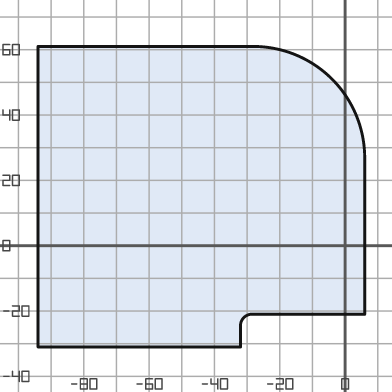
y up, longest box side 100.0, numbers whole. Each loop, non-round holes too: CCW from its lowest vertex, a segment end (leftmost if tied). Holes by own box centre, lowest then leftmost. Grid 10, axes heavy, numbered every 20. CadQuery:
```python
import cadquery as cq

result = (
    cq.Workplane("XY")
    .moveTo(-94.0, -31.0)
    .lineTo(-32.0, -31.0)
    .lineTo(-32.0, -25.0)
    .threePointArc((-31.0, -22.0), (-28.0, -21.0))
    .lineTo(6.0, -21.0)
    .lineTo(6.0, 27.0)
    .threePointArc((-4.0, 51.0), (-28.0, 61.0))
    .lineTo(-94.0, 61.0)
    .close()
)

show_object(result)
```